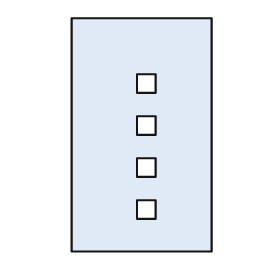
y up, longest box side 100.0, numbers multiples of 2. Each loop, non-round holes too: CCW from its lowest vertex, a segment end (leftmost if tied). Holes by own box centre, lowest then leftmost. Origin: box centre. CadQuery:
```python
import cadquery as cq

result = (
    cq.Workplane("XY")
    .moveTo(-30.0, -50.0)
    .lineTo(30.0, -50.0)
    .lineTo(30.0, 50.0)
    .lineTo(-30.0, 50.0)
    .close()
    .moveTo(-2.0, -36.0)
    .lineTo(6.0, -36.0)
    .lineTo(6.0, -28.0)
    .lineTo(-2.0, -28.0)
    .close()
    .moveTo(-2.0, -18.0)
    .lineTo(6.0, -18.0)
    .lineTo(6.0, -10.0)
    .lineTo(-2.0, -10.0)
    .close()
    .moveTo(-2.0, 0.0)
    .lineTo(6.0, 0.0)
    .lineTo(6.0, 8.0)
    .lineTo(-2.0, 8.0)
    .close()
    .moveTo(-2.0, 18.0)
    .lineTo(6.0, 18.0)
    .lineTo(6.0, 26.0)
    .lineTo(-2.0, 26.0)
    .close()
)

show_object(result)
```